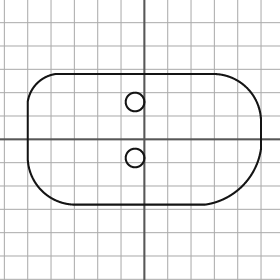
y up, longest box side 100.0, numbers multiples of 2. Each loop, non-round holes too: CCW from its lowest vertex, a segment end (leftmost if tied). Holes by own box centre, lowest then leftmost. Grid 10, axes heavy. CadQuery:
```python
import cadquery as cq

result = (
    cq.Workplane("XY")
    .moveTo(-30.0, -28.0)
    .lineTo(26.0, -28.0)
    .threePointArc((42.0, -20.0), (50.0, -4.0))
    .lineTo(50.0, 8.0)
    .threePointArc((44.0, 22.0), (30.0, 28.0))
    .lineTo(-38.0, 28.0)
    .threePointArc((-46.0, 24.0), (-50.0, 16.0))
    .lineTo(-50.0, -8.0)
    .threePointArc((-44.0, -22.0), (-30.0, -28.0))
    .close()
    .moveTo(-4.0, -8.0)
    .circle(4.0)
    .moveTo(-4.0, 16.0)
    .circle(4.0)
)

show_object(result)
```